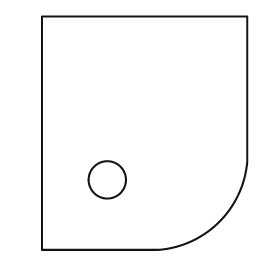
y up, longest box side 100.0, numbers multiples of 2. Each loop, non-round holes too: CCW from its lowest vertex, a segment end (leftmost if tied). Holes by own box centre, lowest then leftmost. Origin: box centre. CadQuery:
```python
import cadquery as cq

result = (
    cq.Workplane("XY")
    .moveTo(-44.0, -50.0)
    .lineTo(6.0, -50.0)
    .threePointArc((32.0, -38.0), (44.0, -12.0))
    .lineTo(44.0, 50.0)
    .lineTo(-44.0, 50.0)
    .close()
    .moveTo(-16.0, -20.0)
    .circle(8.0)
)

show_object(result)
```